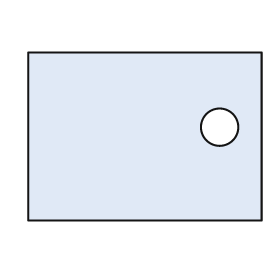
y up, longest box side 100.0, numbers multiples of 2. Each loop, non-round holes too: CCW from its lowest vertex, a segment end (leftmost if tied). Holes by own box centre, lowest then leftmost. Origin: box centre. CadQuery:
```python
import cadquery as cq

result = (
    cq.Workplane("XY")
    .moveTo(-50.0, -36.0)
    .lineTo(50.0, -36.0)
    .lineTo(50.0, 36.0)
    .lineTo(-50.0, 36.0)
    .close()
    .moveTo(32.0, 4.0)
    .circle(8.0)
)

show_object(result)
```